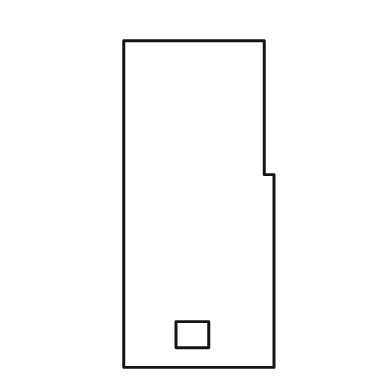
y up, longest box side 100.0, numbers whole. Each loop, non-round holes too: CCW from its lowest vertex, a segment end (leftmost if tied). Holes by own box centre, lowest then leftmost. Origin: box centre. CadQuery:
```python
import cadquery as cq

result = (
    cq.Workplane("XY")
    .moveTo(-23.0, -50.0)
    .lineTo(23.0, -50.0)
    .lineTo(23.0, 9.0)
    .lineTo(20.0, 9.0)
    .lineTo(20.0, 50.0)
    .lineTo(-23.0, 50.0)
    .close()
    .moveTo(-7.0, -44.0)
    .lineTo(3.0, -44.0)
    .lineTo(3.0, -36.0)
    .lineTo(-7.0, -36.0)
    .close()
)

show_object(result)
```